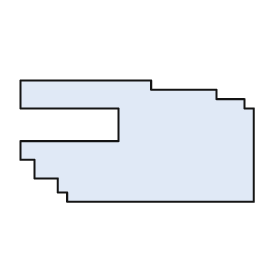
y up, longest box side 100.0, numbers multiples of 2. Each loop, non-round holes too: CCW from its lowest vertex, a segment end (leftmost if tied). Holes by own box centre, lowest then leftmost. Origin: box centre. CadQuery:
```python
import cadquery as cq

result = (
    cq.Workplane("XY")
    .moveTo(-30.0, -26.0)
    .lineTo(50.0, -26.0)
    .lineTo(50.0, 14.0)
    .lineTo(46.0, 14.0)
    .lineTo(46.0, 18.0)
    .lineTo(34.0, 18.0)
    .lineTo(34.0, 22.0)
    .lineTo(6.0, 22.0)
    .lineTo(6.0, 26.0)
    .lineTo(-50.0, 26.0)
    .lineTo(-50.0, 14.0)
    .lineTo(-8.0, 14.0)
    .lineTo(-8.0, 0.0)
    .lineTo(-50.0, 0.0)
    .lineTo(-50.0, -8.0)
    .lineTo(-44.0, -8.0)
    .lineTo(-44.0, -16.0)
    .lineTo(-34.0, -16.0)
    .lineTo(-34.0, -22.0)
    .lineTo(-30.0, -22.0)
    .close()
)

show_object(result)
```